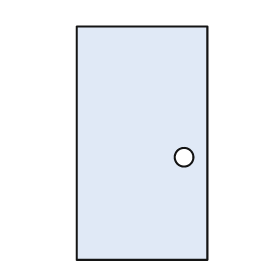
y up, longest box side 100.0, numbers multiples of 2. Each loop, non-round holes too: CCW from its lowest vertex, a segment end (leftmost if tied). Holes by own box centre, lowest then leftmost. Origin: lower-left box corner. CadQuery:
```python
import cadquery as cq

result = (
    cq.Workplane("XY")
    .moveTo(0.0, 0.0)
    .lineTo(56.0, 0.0)
    .lineTo(56.0, 100.0)
    .lineTo(0.0, 100.0)
    .close()
    .moveTo(46.0, 44.0)
    .circle(4.0)
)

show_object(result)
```